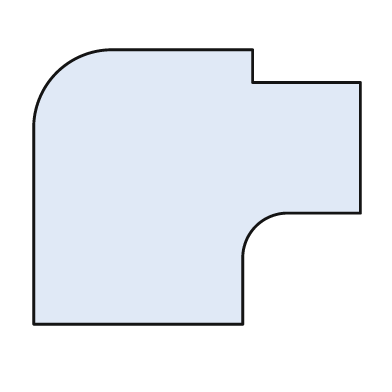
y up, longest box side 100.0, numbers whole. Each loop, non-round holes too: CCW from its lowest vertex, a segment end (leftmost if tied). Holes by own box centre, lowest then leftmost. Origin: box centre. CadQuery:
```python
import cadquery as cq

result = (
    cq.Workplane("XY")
    .moveTo(-50.0, -42.0)
    .lineTo(14.0, -42.0)
    .lineTo(14.0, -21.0)
    .threePointArc((18.0, -12.0), (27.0, -8.0))
    .lineTo(50.0, -8.0)
    .lineTo(50.0, 32.0)
    .lineTo(17.0, 32.0)
    .lineTo(17.0, 42.0)
    .lineTo(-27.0, 42.0)
    .threePointArc((-43.0, 35.0), (-50.0, 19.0))
    .close()
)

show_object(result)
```